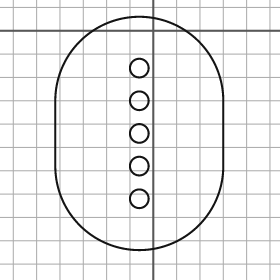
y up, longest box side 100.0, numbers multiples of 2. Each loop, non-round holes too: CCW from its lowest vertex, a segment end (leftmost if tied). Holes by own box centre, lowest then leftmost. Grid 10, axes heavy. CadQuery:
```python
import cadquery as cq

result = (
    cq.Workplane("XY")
    .moveTo(-42.0, -58.0)
    .threePointArc((-6.0, -94.0), (30.0, -58.0))
    .lineTo(30.0, -30.0)
    .threePointArc((-6.0, 6.0), (-42.0, -30.0))
    .close()
    .moveTo(-6.0, -72.0)
    .circle(4.0)
    .moveTo(-6.0, -58.0)
    .circle(4.0)
    .moveTo(-6.0, -44.0)
    .circle(4.0)
    .moveTo(-6.0, -30.0)
    .circle(4.0)
    .moveTo(-6.0, -16.0)
    .circle(4.0)
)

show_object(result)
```